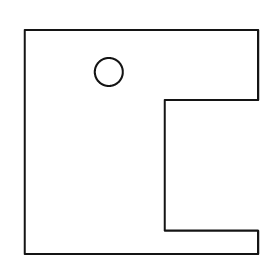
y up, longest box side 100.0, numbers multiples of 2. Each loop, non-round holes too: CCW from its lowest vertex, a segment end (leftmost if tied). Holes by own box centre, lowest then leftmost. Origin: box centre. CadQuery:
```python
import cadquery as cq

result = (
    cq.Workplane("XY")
    .moveTo(-50.0, -48.0)
    .lineTo(50.0, -48.0)
    .lineTo(50.0, -38.0)
    .lineTo(10.0, -38.0)
    .lineTo(10.0, 18.0)
    .lineTo(50.0, 18.0)
    .lineTo(50.0, 48.0)
    .lineTo(-50.0, 48.0)
    .close()
    .moveTo(-14.0, 30.0)
    .circle(6.0)
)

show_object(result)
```